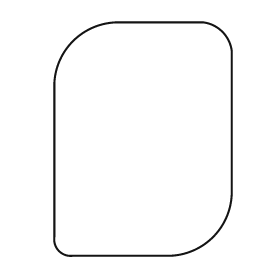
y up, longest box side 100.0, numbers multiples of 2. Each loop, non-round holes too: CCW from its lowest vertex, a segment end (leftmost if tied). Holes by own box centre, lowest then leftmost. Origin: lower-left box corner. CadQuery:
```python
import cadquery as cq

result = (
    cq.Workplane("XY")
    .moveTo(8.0, 0.0)
    .lineTo(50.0, 0.0)
    .threePointArc((68.0, 8.0), (76.0, 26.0))
    .lineTo(76.0, 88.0)
    .threePointArc((72.0, 96.0), (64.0, 100.0))
    .lineTo(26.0, 100.0)
    .threePointArc((8.0, 92.0), (0.0, 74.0))
    .lineTo(0.0, 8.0)
    .threePointArc((2.0, 2.0), (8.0, 0.0))
    .close()
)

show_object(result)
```